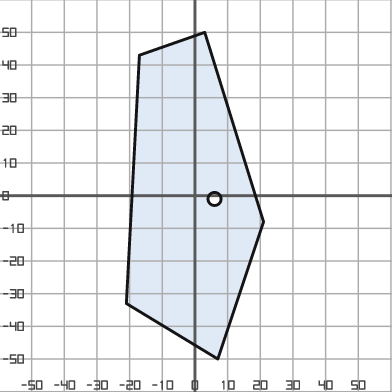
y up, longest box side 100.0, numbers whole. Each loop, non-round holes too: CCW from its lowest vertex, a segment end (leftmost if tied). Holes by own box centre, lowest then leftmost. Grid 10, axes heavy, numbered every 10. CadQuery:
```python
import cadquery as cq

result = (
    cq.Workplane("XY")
    .moveTo(7.0, -50.0)
    .lineTo(21.0, -8.0)
    .lineTo(3.0, 50.0)
    .lineTo(-17.0, 43.0)
    .lineTo(-21.0, -33.0)
    .close()
    .moveTo(6.0, -1.0)
    .circle(2.0)
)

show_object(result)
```